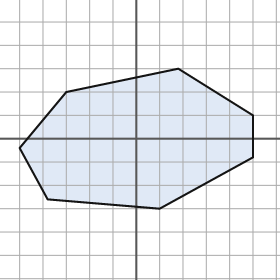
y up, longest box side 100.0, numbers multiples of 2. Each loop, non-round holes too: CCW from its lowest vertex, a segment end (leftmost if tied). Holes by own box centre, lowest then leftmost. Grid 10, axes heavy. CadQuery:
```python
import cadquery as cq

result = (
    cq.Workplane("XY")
    .moveTo(10.0, -30.0)
    .lineTo(50.0, -8.0)
    .lineTo(50.0, 10.0)
    .lineTo(18.0, 30.0)
    .lineTo(-30.0, 20.0)
    .lineTo(-50.0, -4.0)
    .lineTo(-38.0, -26.0)
    .close()
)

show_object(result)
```